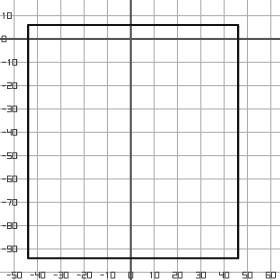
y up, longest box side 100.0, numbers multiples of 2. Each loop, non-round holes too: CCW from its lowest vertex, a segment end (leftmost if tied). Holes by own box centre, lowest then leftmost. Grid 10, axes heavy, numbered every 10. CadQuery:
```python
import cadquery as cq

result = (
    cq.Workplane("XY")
    .moveTo(-44.0, -94.0)
    .lineTo(46.0, -94.0)
    .lineTo(46.0, 6.0)
    .lineTo(-44.0, 6.0)
    .close()
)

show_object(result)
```